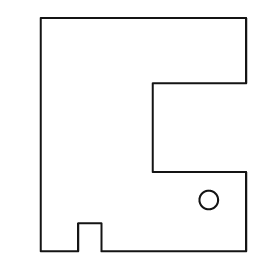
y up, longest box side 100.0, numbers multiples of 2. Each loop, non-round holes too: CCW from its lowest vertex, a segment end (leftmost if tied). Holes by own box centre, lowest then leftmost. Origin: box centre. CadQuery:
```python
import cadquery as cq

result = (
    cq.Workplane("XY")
    .moveTo(-44.0, -50.0)
    .lineTo(-28.0, -50.0)
    .lineTo(-28.0, -38.0)
    .lineTo(-18.0, -38.0)
    .lineTo(-18.0, -50.0)
    .lineTo(44.0, -50.0)
    .lineTo(44.0, -16.0)
    .lineTo(4.0, -16.0)
    .lineTo(4.0, 22.0)
    .lineTo(44.0, 22.0)
    .lineTo(44.0, 50.0)
    .lineTo(-44.0, 50.0)
    .close()
    .moveTo(28.0, -28.0)
    .circle(4.0)
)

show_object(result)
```